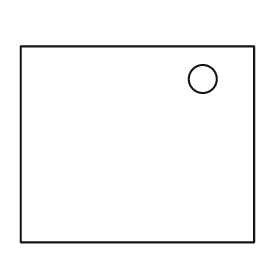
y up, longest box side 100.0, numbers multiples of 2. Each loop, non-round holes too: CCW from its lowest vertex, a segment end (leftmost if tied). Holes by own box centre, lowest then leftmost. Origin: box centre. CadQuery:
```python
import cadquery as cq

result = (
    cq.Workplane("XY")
    .moveTo(-50.0, -42.0)
    .lineTo(50.0, -42.0)
    .lineTo(50.0, 42.0)
    .lineTo(-50.0, 42.0)
    .close()
    .moveTo(28.0, 28.0)
    .circle(6.0)
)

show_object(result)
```